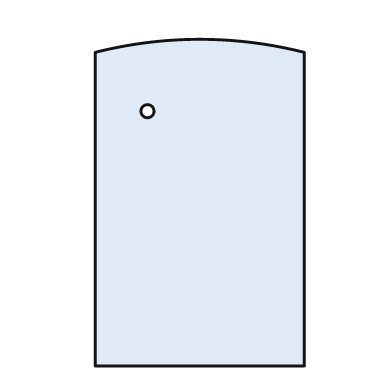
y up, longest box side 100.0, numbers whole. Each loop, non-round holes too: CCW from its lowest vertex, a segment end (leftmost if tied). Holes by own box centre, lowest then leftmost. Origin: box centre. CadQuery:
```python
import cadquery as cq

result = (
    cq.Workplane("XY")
    .moveTo(-32.0, -50.0)
    .lineTo(32.0, -50.0)
    .lineTo(32.0, 46.0)
    .threePointArc((0.0, 50.0), (-32.0, 46.0))
    .close()
    .moveTo(-16.0, 28.0)
    .circle(2.0)
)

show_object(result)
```